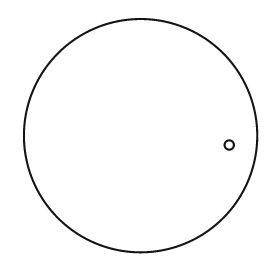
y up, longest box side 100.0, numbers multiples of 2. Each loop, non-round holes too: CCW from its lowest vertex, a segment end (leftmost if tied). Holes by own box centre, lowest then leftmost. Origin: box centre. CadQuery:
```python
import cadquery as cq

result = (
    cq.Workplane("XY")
    .moveTo(0.0, 0.0)
    .circle(50.0)
    .moveTo(38.0, -4.0)
    .circle(2.0)
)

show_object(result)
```